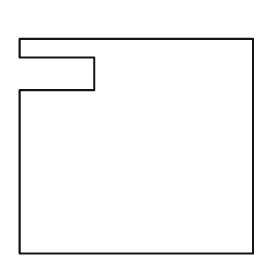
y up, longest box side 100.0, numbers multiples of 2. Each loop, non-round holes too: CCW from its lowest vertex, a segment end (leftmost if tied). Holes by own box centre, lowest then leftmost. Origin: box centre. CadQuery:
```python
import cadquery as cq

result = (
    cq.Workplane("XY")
    .moveTo(-50.0, -46.0)
    .lineTo(50.0, -46.0)
    .lineTo(50.0, 46.0)
    .lineTo(-50.0, 46.0)
    .lineTo(-50.0, 38.0)
    .lineTo(-18.0, 38.0)
    .lineTo(-18.0, 24.0)
    .lineTo(-50.0, 24.0)
    .close()
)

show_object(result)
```